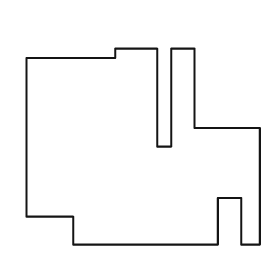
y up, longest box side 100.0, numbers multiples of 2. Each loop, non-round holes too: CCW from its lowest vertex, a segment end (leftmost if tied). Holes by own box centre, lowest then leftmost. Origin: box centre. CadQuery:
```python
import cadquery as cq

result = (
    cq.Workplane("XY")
    .moveTo(-30.0, -42.0)
    .lineTo(32.0, -42.0)
    .lineTo(32.0, -22.0)
    .lineTo(42.0, -22.0)
    .lineTo(42.0, -42.0)
    .lineTo(50.0, -42.0)
    .lineTo(50.0, 8.0)
    .lineTo(22.0, 8.0)
    .lineTo(22.0, 42.0)
    .lineTo(12.0, 42.0)
    .lineTo(12.0, 0.0)
    .lineTo(6.0, 0.0)
    .lineTo(6.0, 42.0)
    .lineTo(-12.0, 42.0)
    .lineTo(-12.0, 38.0)
    .lineTo(-50.0, 38.0)
    .lineTo(-50.0, -30.0)
    .lineTo(-30.0, -30.0)
    .close()
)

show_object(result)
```